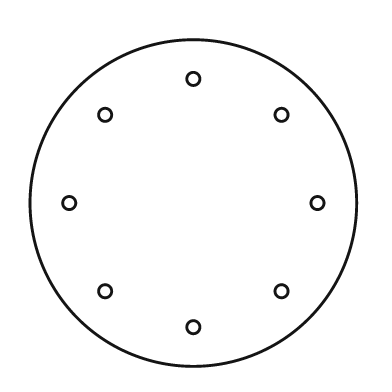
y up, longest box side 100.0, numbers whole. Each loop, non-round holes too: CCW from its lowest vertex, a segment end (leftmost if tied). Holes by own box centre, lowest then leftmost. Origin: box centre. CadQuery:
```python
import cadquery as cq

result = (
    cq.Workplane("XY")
    .moveTo(0.0, 0.0)
    .circle(50.0)
    .moveTo(0.0, -38.0)
    .circle(2.0)
    .moveTo(-27.0, -27.0)
    .circle(2.0)
    .moveTo(27.0, -27.0)
    .circle(2.0)
    .moveTo(-38.0, 0.0)
    .circle(2.0)
    .moveTo(38.0, 0.0)
    .circle(2.0)
    .moveTo(-27.0, 27.0)
    .circle(2.0)
    .moveTo(27.0, 27.0)
    .circle(2.0)
    .moveTo(0.0, 38.0)
    .circle(2.0)
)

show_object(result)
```